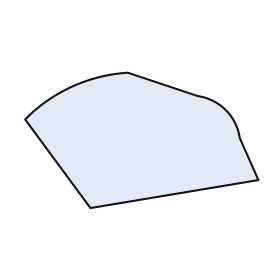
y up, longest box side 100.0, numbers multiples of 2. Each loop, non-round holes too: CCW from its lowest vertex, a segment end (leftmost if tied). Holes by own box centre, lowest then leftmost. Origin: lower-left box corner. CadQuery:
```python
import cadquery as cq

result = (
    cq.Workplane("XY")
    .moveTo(28.0, 0.0)
    .lineTo(100.0, 12.0)
    .lineTo(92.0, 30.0)
    .threePointArc((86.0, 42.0), (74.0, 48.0))
    .lineTo(44.0, 58.0)
    .threePointArc((20.0, 52.0), (0.0, 38.0))
    .close()
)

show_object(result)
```